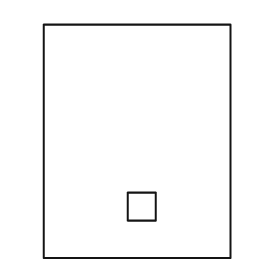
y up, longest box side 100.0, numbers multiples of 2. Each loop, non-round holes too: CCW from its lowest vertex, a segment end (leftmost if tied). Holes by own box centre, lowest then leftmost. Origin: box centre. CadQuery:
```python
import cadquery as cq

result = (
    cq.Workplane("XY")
    .moveTo(-40.0, -50.0)
    .lineTo(40.0, -50.0)
    .lineTo(40.0, 50.0)
    .lineTo(-40.0, 50.0)
    .close()
    .moveTo(-4.0, -34.0)
    .lineTo(8.0, -34.0)
    .lineTo(8.0, -22.0)
    .lineTo(-4.0, -22.0)
    .close()
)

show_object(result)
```